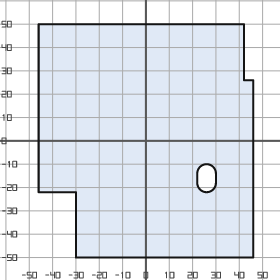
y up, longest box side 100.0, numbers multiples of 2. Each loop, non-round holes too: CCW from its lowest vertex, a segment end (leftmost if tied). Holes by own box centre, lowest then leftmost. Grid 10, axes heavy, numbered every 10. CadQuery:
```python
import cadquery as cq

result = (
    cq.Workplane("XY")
    .moveTo(-30.0, -50.0)
    .lineTo(46.0, -50.0)
    .lineTo(46.0, 26.0)
    .lineTo(42.0, 26.0)
    .lineTo(42.0, 50.0)
    .lineTo(-46.0, 50.0)
    .lineTo(-46.0, -22.0)
    .lineTo(-30.0, -22.0)
    .close()
    .moveTo(22.0, -18.0)
    .threePointArc((26.0, -22.0), (30.0, -18.0))
    .lineTo(30.0, -14.0)
    .threePointArc((26.0, -10.0), (22.0, -14.0))
    .close()
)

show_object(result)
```